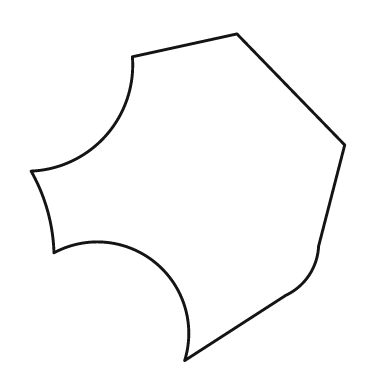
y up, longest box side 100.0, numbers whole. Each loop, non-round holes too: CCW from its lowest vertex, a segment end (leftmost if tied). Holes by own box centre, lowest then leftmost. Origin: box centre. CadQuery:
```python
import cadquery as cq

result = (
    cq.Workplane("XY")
    .moveTo(-1.0, -50.0)
    .lineTo(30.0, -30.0)
    .threePointArc((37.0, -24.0), (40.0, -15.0))
    .lineTo(48.0, 16.0)
    .lineTo(15.0, 50.0)
    .lineTo(-17.0, 43.0)
    .threePointArc((-25.0, 19.0), (-48.0, 8.0))
    .threePointArc((-43.0, -4.0), (-41.0, -17.0))
    .threePointArc((-10.0, -20.0), (-1.0, -50.0))
    .close()
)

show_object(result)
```